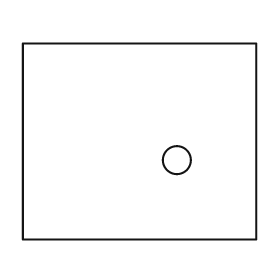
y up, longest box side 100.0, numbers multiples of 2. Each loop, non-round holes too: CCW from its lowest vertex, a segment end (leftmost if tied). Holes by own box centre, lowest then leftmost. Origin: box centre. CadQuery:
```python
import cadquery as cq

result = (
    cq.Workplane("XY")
    .moveTo(-50.0, -42.0)
    .lineTo(50.0, -42.0)
    .lineTo(50.0, 42.0)
    .lineTo(-50.0, 42.0)
    .close()
    .moveTo(16.0, -8.0)
    .circle(6.0)
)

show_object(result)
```